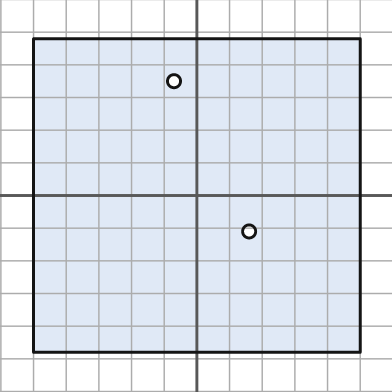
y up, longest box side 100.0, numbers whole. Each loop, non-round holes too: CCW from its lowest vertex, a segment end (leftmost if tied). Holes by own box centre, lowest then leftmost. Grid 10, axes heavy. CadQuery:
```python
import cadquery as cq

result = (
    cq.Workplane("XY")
    .moveTo(-50.0, -48.0)
    .lineTo(50.0, -48.0)
    .lineTo(50.0, 48.0)
    .lineTo(-50.0, 48.0)
    .close()
    .moveTo(16.0, -11.0)
    .circle(2.0)
    .moveTo(-7.0, 35.0)
    .circle(2.0)
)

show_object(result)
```